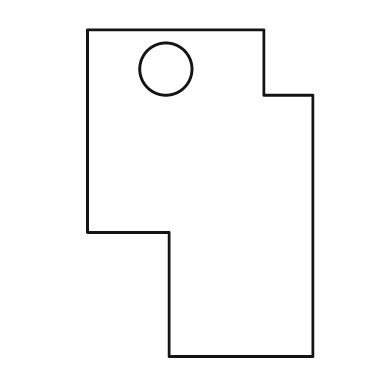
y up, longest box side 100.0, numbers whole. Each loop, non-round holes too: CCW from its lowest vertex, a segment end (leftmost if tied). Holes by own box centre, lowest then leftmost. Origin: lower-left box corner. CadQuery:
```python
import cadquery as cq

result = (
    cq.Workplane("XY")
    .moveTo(25.0, 0.0)
    .lineTo(69.0, 0.0)
    .lineTo(69.0, 80.0)
    .lineTo(54.0, 80.0)
    .lineTo(54.0, 100.0)
    .lineTo(0.0, 100.0)
    .lineTo(0.0, 38.0)
    .lineTo(25.0, 38.0)
    .close()
    .moveTo(24.0, 88.0)
    .circle(8.0)
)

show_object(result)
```